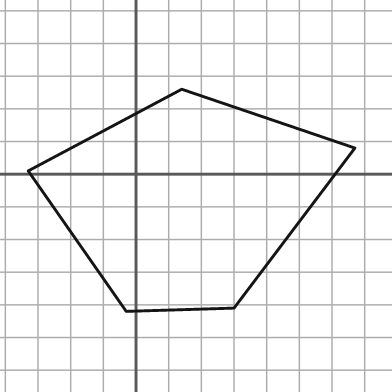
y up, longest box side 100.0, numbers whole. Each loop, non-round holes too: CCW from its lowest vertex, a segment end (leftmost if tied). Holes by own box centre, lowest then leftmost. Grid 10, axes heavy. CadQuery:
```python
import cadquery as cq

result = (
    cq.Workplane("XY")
    .moveTo(-3.0, -42.0)
    .lineTo(30.0, -41.0)
    .lineTo(67.0, 8.0)
    .lineTo(14.0, 26.0)
    .lineTo(-33.0, 1.0)
    .close()
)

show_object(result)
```